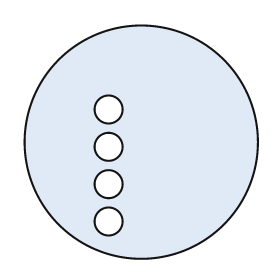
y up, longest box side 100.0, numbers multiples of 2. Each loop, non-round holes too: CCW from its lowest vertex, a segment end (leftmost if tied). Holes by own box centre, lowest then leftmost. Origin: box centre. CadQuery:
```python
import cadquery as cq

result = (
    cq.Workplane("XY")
    .moveTo(0.0, 0.0)
    .circle(50.0)
    .moveTo(-14.0, -34.0)
    .circle(6.0)
    .moveTo(-14.0, -18.0)
    .circle(6.0)
    .moveTo(-14.0, -2.0)
    .circle(6.0)
    .moveTo(-14.0, 14.0)
    .circle(6.0)
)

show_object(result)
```